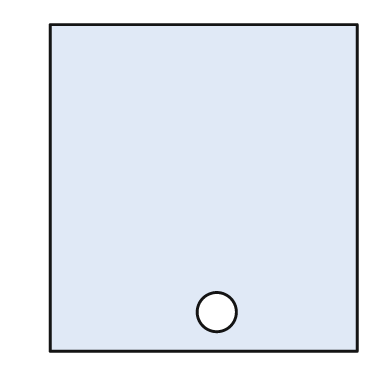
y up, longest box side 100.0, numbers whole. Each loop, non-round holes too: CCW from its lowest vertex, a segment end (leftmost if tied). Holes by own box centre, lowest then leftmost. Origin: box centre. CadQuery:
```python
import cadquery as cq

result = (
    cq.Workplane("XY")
    .moveTo(-47.0, -50.0)
    .lineTo(47.0, -50.0)
    .lineTo(47.0, 50.0)
    .lineTo(-47.0, 50.0)
    .close()
    .moveTo(4.0, -38.0)
    .circle(6.0)
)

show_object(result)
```